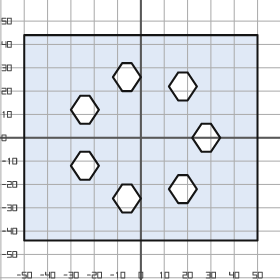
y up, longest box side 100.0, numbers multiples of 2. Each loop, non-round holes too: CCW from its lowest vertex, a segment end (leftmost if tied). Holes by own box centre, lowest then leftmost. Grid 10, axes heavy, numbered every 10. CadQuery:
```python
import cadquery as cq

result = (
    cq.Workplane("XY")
    .moveTo(-50.0, -44.0)
    .lineTo(50.0, -44.0)
    .lineTo(50.0, 44.0)
    .lineTo(-50.0, 44.0)
    .close()
    .moveTo(-8.0, -32.0)
    .lineTo(-4.0, -32.0)
    .lineTo(0.0, -26.0)
    .lineTo(-4.0, -20.0)
    .lineTo(-8.0, -20.0)
    .lineTo(-12.0, -26.0)
    .close()
    .moveTo(16.0, -28.0)
    .lineTo(20.0, -28.0)
    .lineTo(24.0, -22.0)
    .lineTo(20.0, -16.0)
    .lineTo(16.0, -16.0)
    .lineTo(12.0, -22.0)
    .close()
    .moveTo(-26.0, -18.0)
    .lineTo(-22.0, -18.0)
    .lineTo(-18.0, -12.0)
    .lineTo(-22.0, -6.0)
    .lineTo(-26.0, -6.0)
    .lineTo(-30.0, -12.0)
    .close()
    .moveTo(26.0, -6.0)
    .lineTo(30.0, -6.0)
    .lineTo(34.0, 0.0)
    .lineTo(30.0, 6.0)
    .lineTo(26.0, 6.0)
    .lineTo(22.0, 0.0)
    .close()
    .moveTo(-26.0, 6.0)
    .lineTo(-22.0, 6.0)
    .lineTo(-18.0, 12.0)
    .lineTo(-22.0, 18.0)
    .lineTo(-26.0, 18.0)
    .lineTo(-30.0, 12.0)
    .close()
    .moveTo(16.0, 16.0)
    .lineTo(20.0, 16.0)
    .lineTo(24.0, 22.0)
    .lineTo(20.0, 28.0)
    .lineTo(16.0, 28.0)
    .lineTo(12.0, 22.0)
    .close()
    .moveTo(-8.0, 20.0)
    .lineTo(-4.0, 20.0)
    .lineTo(0.0, 26.0)
    .lineTo(-4.0, 32.0)
    .lineTo(-8.0, 32.0)
    .lineTo(-12.0, 26.0)
    .close()
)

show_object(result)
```